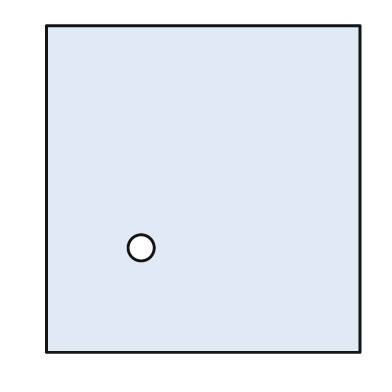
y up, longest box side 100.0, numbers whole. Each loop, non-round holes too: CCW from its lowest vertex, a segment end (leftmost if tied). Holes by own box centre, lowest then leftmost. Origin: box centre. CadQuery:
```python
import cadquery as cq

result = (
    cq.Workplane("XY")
    .moveTo(-48.0, -50.0)
    .lineTo(48.0, -50.0)
    .lineTo(48.0, 50.0)
    .lineTo(-48.0, 50.0)
    .close()
    .moveTo(-19.0, -18.0)
    .circle(4.0)
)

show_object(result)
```